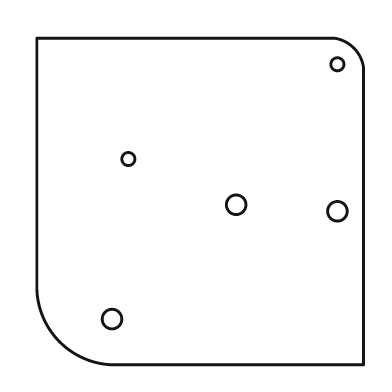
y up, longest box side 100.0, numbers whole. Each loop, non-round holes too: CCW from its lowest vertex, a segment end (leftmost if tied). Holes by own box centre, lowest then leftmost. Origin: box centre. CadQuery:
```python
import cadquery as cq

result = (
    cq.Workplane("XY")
    .moveTo(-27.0, -50.0)
    .lineTo(50.0, -50.0)
    .lineTo(50.0, 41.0)
    .threePointArc((47.0, 47.0), (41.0, 50.0))
    .lineTo(-50.0, 50.0)
    .lineTo(-50.0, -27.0)
    .threePointArc((-43.0, -43.0), (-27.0, -50.0))
    .close()
    .moveTo(-27.0, -36.0)
    .circle(3.0)
    .moveTo(42.0, -3.0)
    .circle(3.0)
    .moveTo(11.0, -1.0)
    .circle(3.0)
    .moveTo(-22.0, 13.0)
    .circle(2.0)
    .moveTo(42.0, 42.0)
    .circle(2.0)
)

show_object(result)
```